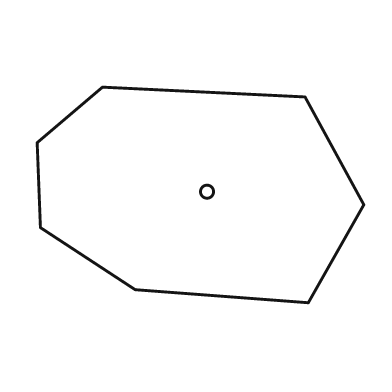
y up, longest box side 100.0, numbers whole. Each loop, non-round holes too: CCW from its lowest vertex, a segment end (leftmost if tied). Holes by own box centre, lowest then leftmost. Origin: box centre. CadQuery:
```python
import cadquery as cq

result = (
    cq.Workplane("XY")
    .moveTo(33.0, -33.0)
    .lineTo(50.0, -3.0)
    .lineTo(32.0, 30.0)
    .lineTo(-30.0, 33.0)
    .lineTo(-50.0, 16.0)
    .lineTo(-49.0, -10.0)
    .lineTo(-20.0, -29.0)
    .close()
    .moveTo(2.0, 1.0)
    .circle(2.0)
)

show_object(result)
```